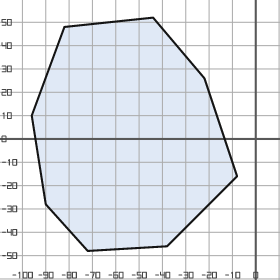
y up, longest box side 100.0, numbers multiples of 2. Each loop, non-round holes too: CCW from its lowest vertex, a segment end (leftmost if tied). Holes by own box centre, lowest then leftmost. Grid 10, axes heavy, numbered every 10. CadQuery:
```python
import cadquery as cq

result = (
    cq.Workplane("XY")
    .moveTo(-72.0, -48.0)
    .lineTo(-38.0, -46.0)
    .lineTo(-8.0, -16.0)
    .lineTo(-22.0, 26.0)
    .lineTo(-44.0, 52.0)
    .lineTo(-82.0, 48.0)
    .lineTo(-96.0, 10.0)
    .lineTo(-90.0, -28.0)
    .close()
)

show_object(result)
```